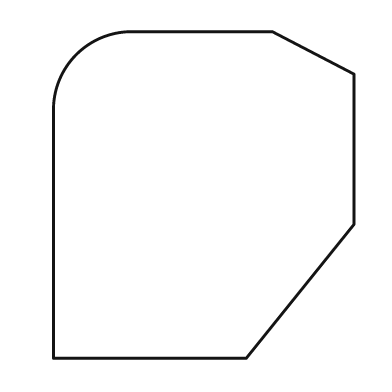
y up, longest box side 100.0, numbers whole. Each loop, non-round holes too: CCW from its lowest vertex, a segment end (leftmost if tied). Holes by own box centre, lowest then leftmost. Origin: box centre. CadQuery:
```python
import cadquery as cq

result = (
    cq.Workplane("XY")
    .moveTo(-46.0, -50.0)
    .lineTo(13.0, -50.0)
    .lineTo(46.0, -9.0)
    .lineTo(46.0, 37.0)
    .lineTo(21.0, 50.0)
    .lineTo(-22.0, 50.0)
    .threePointArc((-39.0, 43.0), (-46.0, 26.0))
    .close()
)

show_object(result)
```